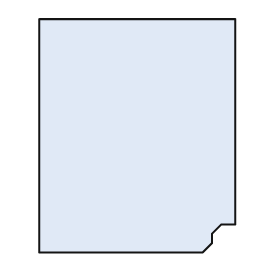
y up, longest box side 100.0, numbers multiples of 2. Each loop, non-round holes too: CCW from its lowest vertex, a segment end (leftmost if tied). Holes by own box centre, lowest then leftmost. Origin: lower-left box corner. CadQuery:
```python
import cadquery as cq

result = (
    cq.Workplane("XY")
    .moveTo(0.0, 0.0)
    .lineTo(70.0, 0.0)
    .lineTo(74.0, 4.0)
    .lineTo(74.0, 8.0)
    .lineTo(78.0, 12.0)
    .lineTo(84.0, 12.0)
    .lineTo(84.0, 100.0)
    .lineTo(0.0, 100.0)
    .close()
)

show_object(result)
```